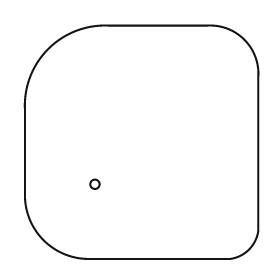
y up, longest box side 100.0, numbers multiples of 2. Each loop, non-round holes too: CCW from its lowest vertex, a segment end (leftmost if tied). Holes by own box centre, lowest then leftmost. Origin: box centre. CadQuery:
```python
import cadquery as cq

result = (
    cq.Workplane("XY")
    .moveTo(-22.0, -50.0)
    .lineTo(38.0, -50.0)
    .threePointArc((46.0, -46.0), (50.0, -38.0))
    .lineTo(50.0, 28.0)
    .threePointArc((44.0, 44.0), (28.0, 50.0))
    .lineTo(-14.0, 50.0)
    .threePointArc((-40.0, 40.0), (-50.0, 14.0))
    .lineTo(-50.0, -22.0)
    .threePointArc((-42.0, -42.0), (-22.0, -50.0))
    .close()
    .moveTo(-20.0, -18.0)
    .circle(2.0)
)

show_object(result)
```